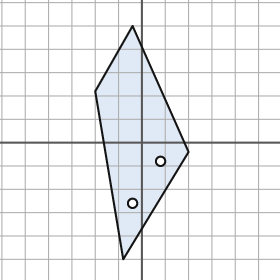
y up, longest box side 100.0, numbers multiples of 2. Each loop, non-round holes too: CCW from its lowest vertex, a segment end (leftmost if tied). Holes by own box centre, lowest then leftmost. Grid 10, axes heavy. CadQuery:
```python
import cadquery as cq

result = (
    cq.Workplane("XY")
    .moveTo(-8.0, -50.0)
    .lineTo(20.0, -4.0)
    .lineTo(-4.0, 50.0)
    .lineTo(-20.0, 22.0)
    .close()
    .moveTo(-4.0, -26.0)
    .circle(2.0)
    .moveTo(8.0, -8.0)
    .circle(2.0)
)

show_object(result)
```